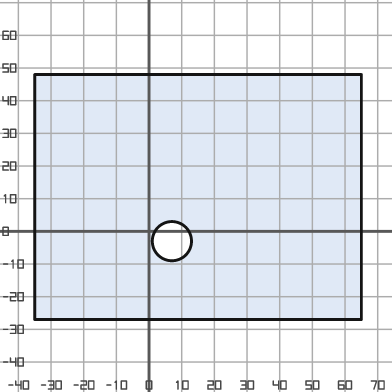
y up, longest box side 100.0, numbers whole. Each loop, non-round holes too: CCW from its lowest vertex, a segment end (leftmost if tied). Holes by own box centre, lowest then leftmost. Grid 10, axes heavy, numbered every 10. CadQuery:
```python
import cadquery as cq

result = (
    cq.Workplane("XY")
    .moveTo(-35.0, -27.0)
    .lineTo(65.0, -27.0)
    .lineTo(65.0, 48.0)
    .lineTo(-35.0, 48.0)
    .close()
    .moveTo(7.0, -3.0)
    .circle(6.0)
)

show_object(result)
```